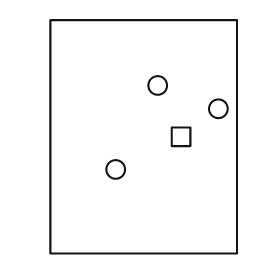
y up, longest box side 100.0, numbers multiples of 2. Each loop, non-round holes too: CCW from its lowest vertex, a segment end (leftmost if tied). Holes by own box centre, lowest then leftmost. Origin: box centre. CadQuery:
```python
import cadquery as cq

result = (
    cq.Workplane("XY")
    .moveTo(-40.0, -50.0)
    .lineTo(40.0, -50.0)
    .lineTo(40.0, 50.0)
    .lineTo(-40.0, 50.0)
    .close()
    .moveTo(-12.0, -14.0)
    .circle(4.0)
    .moveTo(12.0, -4.0)
    .lineTo(20.0, -4.0)
    .lineTo(20.0, 4.0)
    .lineTo(12.0, 4.0)
    .close()
    .moveTo(32.0, 12.0)
    .circle(4.0)
    .moveTo(6.0, 22.0)
    .circle(4.0)
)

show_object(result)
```